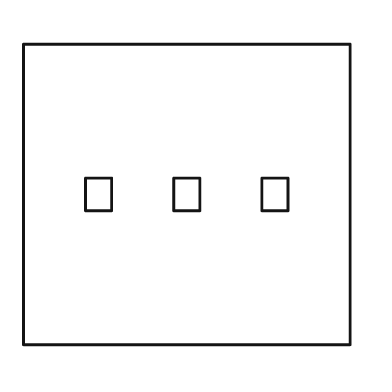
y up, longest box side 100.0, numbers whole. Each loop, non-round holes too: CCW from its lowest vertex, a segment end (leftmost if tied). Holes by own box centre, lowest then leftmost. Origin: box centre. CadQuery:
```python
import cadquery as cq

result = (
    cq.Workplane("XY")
    .moveTo(-50.0, -46.0)
    .lineTo(50.0, -46.0)
    .lineTo(50.0, 46.0)
    .lineTo(-50.0, 46.0)
    .close()
    .moveTo(-31.0, -5.0)
    .lineTo(-23.0, -5.0)
    .lineTo(-23.0, 5.0)
    .lineTo(-31.0, 5.0)
    .close()
    .moveTo(-4.0, -5.0)
    .lineTo(4.0, -5.0)
    .lineTo(4.0, 5.0)
    .lineTo(-4.0, 5.0)
    .close()
    .moveTo(23.0, -5.0)
    .lineTo(31.0, -5.0)
    .lineTo(31.0, 5.0)
    .lineTo(23.0, 5.0)
    .close()
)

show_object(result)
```